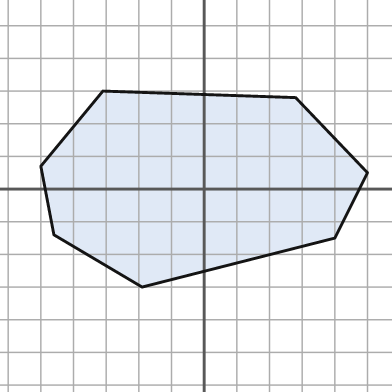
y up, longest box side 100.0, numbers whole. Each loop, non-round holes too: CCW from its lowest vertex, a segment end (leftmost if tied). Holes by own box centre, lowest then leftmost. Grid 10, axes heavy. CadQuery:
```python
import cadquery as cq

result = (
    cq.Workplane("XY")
    .moveTo(-19.0, -30.0)
    .lineTo(40.0, -15.0)
    .lineTo(50.0, 5.0)
    .lineTo(28.0, 28.0)
    .lineTo(-31.0, 30.0)
    .lineTo(-50.0, 7.0)
    .lineTo(-46.0, -14.0)
    .close()
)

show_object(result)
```